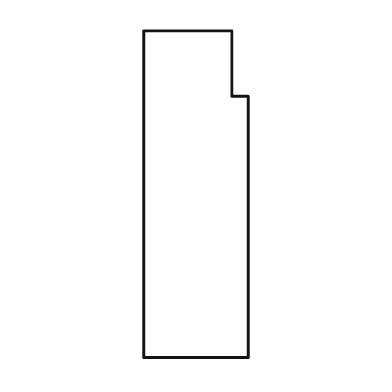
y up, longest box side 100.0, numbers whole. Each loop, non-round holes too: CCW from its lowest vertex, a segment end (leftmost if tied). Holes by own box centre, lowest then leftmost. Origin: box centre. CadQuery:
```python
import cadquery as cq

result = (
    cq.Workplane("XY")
    .moveTo(-16.0, -50.0)
    .lineTo(16.0, -50.0)
    .lineTo(16.0, 30.0)
    .lineTo(11.0, 30.0)
    .lineTo(11.0, 50.0)
    .lineTo(-16.0, 50.0)
    .close()
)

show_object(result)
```